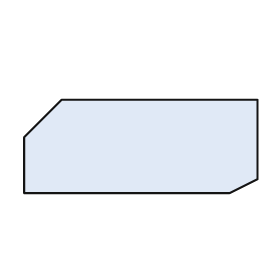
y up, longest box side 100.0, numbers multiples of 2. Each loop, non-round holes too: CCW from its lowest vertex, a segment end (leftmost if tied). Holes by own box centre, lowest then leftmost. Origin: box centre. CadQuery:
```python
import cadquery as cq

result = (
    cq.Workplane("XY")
    .moveTo(-50.0, -20.0)
    .lineTo(38.0, -20.0)
    .lineTo(50.0, -14.0)
    .lineTo(50.0, 20.0)
    .lineTo(-34.0, 20.0)
    .lineTo(-50.0, 4.0)
    .close()
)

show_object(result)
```